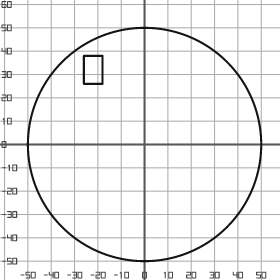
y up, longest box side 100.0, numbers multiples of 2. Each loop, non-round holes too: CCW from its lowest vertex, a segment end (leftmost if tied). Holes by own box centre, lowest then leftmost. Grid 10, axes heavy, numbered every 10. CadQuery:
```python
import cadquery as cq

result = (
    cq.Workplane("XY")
    .moveTo(0.0, 0.0)
    .circle(50.0)
    .moveTo(-26.0, 26.0)
    .lineTo(-18.0, 26.0)
    .lineTo(-18.0, 38.0)
    .lineTo(-26.0, 38.0)
    .close()
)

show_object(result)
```